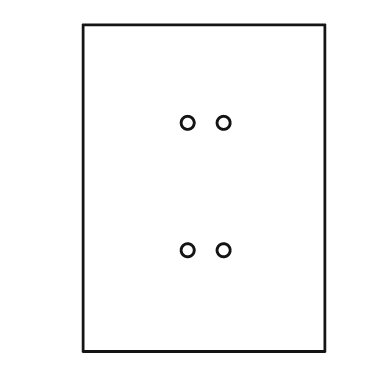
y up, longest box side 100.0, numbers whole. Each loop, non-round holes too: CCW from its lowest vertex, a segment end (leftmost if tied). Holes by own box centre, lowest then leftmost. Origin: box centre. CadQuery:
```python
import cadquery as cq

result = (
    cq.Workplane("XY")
    .moveTo(-37.0, -50.0)
    .lineTo(37.0, -50.0)
    .lineTo(37.0, 50.0)
    .lineTo(-37.0, 50.0)
    .close()
    .moveTo(-5.0, -19.0)
    .circle(2.0)
    .moveTo(6.0, -19.0)
    .circle(2.0)
    .moveTo(-5.0, 20.0)
    .circle(2.0)
    .moveTo(6.0, 20.0)
    .circle(2.0)
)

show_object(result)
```